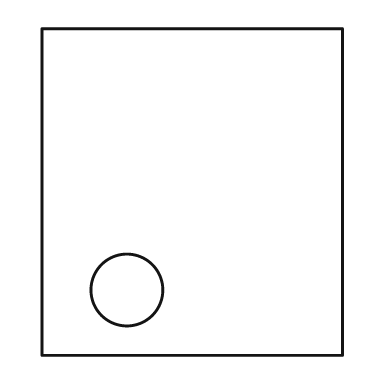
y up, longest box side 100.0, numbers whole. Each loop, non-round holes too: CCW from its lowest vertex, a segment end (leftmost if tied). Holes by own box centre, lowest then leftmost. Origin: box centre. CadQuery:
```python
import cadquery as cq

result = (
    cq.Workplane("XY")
    .moveTo(-46.0, -50.0)
    .lineTo(46.0, -50.0)
    .lineTo(46.0, 50.0)
    .lineTo(-46.0, 50.0)
    .close()
    .moveTo(-20.0, -30.0)
    .circle(11.0)
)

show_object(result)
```